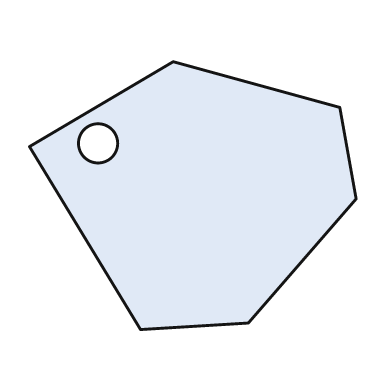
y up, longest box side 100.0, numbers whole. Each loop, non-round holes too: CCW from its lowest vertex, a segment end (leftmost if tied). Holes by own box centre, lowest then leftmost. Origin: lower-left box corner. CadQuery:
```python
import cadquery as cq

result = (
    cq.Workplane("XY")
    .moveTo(34.0, 0.0)
    .lineTo(67.0, 2.0)
    .lineTo(100.0, 40.0)
    .lineTo(95.0, 68.0)
    .lineTo(44.0, 82.0)
    .lineTo(0.0, 56.0)
    .close()
    .moveTo(21.0, 57.0)
    .circle(6.0)
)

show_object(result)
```